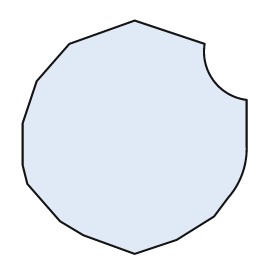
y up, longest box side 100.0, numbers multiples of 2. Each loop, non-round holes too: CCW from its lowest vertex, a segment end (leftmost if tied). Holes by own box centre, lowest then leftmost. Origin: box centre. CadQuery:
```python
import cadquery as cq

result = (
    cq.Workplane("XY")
    .moveTo(0.0, -50.0)
    .lineTo(18.0, -44.0)
    .lineTo(34.0, -34.0)
    .lineTo(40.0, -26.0)
    .threePointArc((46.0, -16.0), (48.0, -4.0))
    .lineTo(48.0, 16.0)
    .threePointArc((34.0, 24.0), (30.0, 40.0))
    .lineTo(0.0, 50.0)
    .lineTo(-28.0, 40.0)
    .lineTo(-42.0, 24.0)
    .lineTo(-48.0, 6.0)
    .lineTo(-48.0, -12.0)
    .lineTo(-46.0, -20.0)
    .lineTo(-32.0, -36.0)
    .lineTo(-22.0, -42.0)
    .close()
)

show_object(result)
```